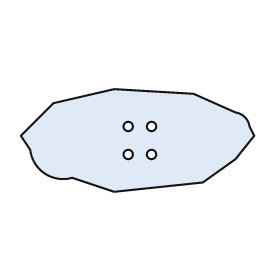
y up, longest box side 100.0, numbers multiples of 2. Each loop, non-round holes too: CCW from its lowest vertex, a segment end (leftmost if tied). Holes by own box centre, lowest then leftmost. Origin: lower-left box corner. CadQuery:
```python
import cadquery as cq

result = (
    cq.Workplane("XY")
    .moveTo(40.0, 0.0)
    .lineTo(78.0, 4.0)
    .lineTo(92.0, 14.0)
    .lineTo(100.0, 24.0)
    .lineTo(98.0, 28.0)
    .threePointArc((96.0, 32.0), (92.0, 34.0))
    .lineTo(74.0, 42.0)
    .lineTo(40.0, 44.0)
    .lineTo(14.0, 38.0)
    .lineTo(0.0, 24.0)
    .lineTo(4.0, 18.0)
    .threePointArc((10.0, 8.0), (22.0, 6.0))
    .close()
    .moveTo(46.0, 16.0)
    .circle(2.0)
    .moveTo(56.0, 16.0)
    .circle(2.0)
    .moveTo(46.0, 28.0)
    .circle(2.0)
    .moveTo(56.0, 28.0)
    .circle(2.0)
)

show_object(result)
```